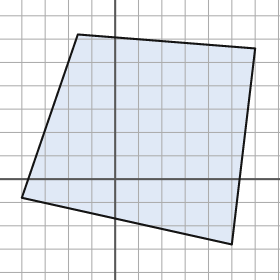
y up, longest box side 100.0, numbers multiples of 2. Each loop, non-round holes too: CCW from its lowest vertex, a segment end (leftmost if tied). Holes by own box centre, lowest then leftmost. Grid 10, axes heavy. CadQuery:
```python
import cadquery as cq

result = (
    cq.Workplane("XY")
    .moveTo(50.0, -28.0)
    .lineTo(60.0, 56.0)
    .lineTo(-16.0, 62.0)
    .lineTo(-40.0, -8.0)
    .close()
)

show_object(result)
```